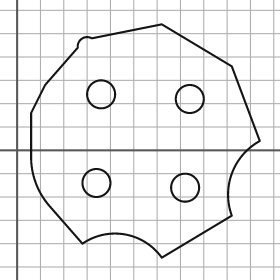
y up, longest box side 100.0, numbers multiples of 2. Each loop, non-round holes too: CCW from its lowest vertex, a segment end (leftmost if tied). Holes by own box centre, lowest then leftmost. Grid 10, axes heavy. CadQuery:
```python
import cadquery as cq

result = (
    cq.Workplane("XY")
    .moveTo(62.0, -46.0)
    .lineTo(92.0, -28.0)
    .threePointArc((92.0, -10.0), (104.0, 4.0))
    .lineTo(92.0, 36.0)
    .lineTo(62.0, 54.0)
    .lineTo(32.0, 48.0)
    .threePointArc((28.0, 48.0), (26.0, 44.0))
    .lineTo(12.0, 28.0)
    .lineTo(6.0, 16.0)
    .lineTo(6.0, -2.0)
    .threePointArc((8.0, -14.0), (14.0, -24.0))
    .lineTo(28.0, -40.0)
    .threePointArc((46.0, -36.0), (62.0, -46.0))
    .close()
    .moveTo(72.0, -16.0)
    .circle(6.0)
    .moveTo(34.0, -14.0)
    .circle(6.0)
    .moveTo(74.0, 22.0)
    .circle(6.0)
    .moveTo(36.0, 24.0)
    .circle(6.0)
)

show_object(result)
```